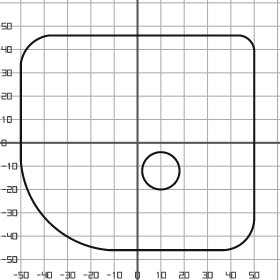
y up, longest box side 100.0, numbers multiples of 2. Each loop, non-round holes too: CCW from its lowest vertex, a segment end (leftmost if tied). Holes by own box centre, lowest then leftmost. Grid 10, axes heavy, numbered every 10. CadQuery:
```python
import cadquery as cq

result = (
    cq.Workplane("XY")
    .moveTo(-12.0, -46.0)
    .lineTo(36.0, -46.0)
    .threePointArc((46.0, -42.0), (50.0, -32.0))
    .lineTo(50.0, 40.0)
    .threePointArc((48.0, 44.0), (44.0, 46.0))
    .lineTo(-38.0, 46.0)
    .threePointArc((-46.0, 42.0), (-50.0, 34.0))
    .lineTo(-50.0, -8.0)
    .threePointArc((-38.0, -34.0), (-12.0, -46.0))
    .close()
    .moveTo(10.0, -12.0)
    .circle(8.0)
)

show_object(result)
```